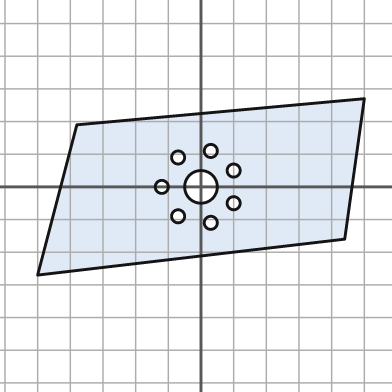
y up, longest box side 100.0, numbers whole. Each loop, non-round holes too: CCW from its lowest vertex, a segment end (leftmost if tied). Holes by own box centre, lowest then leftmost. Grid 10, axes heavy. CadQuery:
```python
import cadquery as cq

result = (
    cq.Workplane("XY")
    .moveTo(-50.0, -27.0)
    .lineTo(44.0, -16.0)
    .lineTo(50.0, 27.0)
    .lineTo(-38.0, 19.0)
    .close()
    .moveTo(3.0, -11.0)
    .circle(2.0)
    .moveTo(-7.0, -9.0)
    .circle(2.0)
    .moveTo(10.0, -5.0)
    .circle(2.0)
    .moveTo(-12.0, 0.0)
    .circle(2.0)
    .moveTo(0.0, 0.0)
    .circle(5.0)
    .moveTo(10.0, 5.0)
    .circle(2.0)
    .moveTo(-7.0, 9.0)
    .circle(2.0)
    .moveTo(3.0, 11.0)
    .circle(2.0)
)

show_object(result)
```